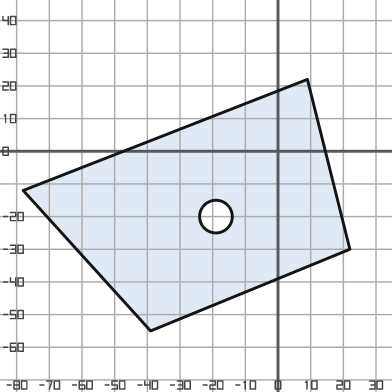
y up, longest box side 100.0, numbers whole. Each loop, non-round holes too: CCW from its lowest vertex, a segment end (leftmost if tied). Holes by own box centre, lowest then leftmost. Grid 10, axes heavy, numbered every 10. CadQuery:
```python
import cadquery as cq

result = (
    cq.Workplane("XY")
    .moveTo(-39.0, -55.0)
    .lineTo(22.0, -30.0)
    .lineTo(9.0, 22.0)
    .lineTo(-78.0, -12.0)
    .close()
    .moveTo(-19.0, -20.0)
    .circle(5.0)
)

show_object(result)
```